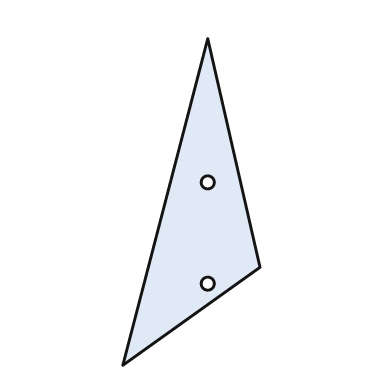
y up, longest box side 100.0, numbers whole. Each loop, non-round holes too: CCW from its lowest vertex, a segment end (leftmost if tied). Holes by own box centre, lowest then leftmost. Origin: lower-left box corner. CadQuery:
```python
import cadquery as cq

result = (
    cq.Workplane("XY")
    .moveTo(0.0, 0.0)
    .lineTo(42.0, 30.0)
    .lineTo(26.0, 100.0)
    .close()
    .moveTo(26.0, 25.0)
    .circle(2.0)
    .moveTo(26.0, 56.0)
    .circle(2.0)
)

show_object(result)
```